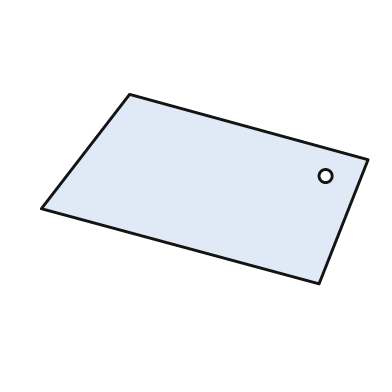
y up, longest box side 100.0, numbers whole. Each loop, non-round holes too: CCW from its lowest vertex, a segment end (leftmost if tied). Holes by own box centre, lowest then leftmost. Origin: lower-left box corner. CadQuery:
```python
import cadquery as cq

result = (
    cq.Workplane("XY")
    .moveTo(85.0, 0.0)
    .lineTo(100.0, 38.0)
    .lineTo(27.0, 58.0)
    .lineTo(0.0, 23.0)
    .close()
    .moveTo(87.0, 33.0)
    .circle(2.0)
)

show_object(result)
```